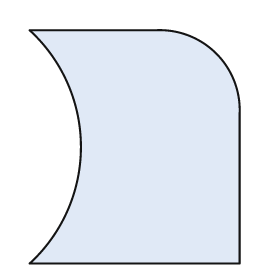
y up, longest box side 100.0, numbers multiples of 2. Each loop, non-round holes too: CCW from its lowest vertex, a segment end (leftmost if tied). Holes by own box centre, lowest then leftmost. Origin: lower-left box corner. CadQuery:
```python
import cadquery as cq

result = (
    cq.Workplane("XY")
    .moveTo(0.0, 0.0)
    .lineTo(90.0, 0.0)
    .lineTo(90.0, 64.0)
    .threePointArc((80.0, 90.0), (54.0, 100.0))
    .lineTo(0.0, 100.0)
    .threePointArc((22.0, 50.0), (0.0, 0.0))
    .close()
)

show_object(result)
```